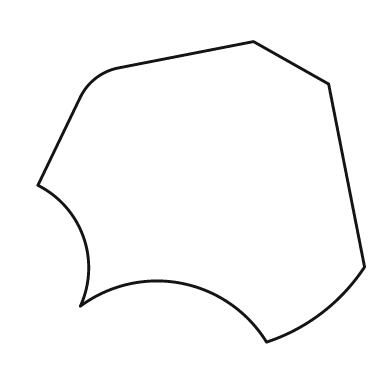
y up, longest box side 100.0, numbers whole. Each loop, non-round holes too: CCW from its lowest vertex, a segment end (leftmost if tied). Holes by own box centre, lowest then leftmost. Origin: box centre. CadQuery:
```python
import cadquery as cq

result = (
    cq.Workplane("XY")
    .moveTo(20.0, -46.0)
    .threePointArc((37.0, -37.0), (50.0, -23.0))
    .lineTo(39.0, 33.0)
    .lineTo(16.0, 46.0)
    .lineTo(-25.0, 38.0)
    .threePointArc((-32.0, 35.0), (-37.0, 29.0))
    .lineTo(-50.0, 2.0)
    .threePointArc((-36.0, -14.0), (-37.0, -35.0))
    .threePointArc((-6.0, -28.0), (20.0, -46.0))
    .close()
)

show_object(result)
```